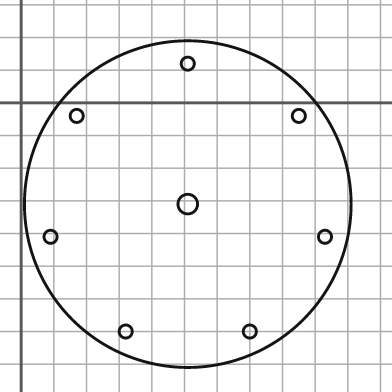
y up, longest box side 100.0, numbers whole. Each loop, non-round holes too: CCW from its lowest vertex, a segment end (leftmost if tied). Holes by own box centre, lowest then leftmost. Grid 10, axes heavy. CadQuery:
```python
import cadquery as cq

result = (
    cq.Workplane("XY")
    .moveTo(51.0, -31.0)
    .circle(50.0)
    .moveTo(32.0, -70.0)
    .circle(2.0)
    .moveTo(70.0, -70.0)
    .circle(2.0)
    .moveTo(9.0, -41.0)
    .circle(2.0)
    .moveTo(93.0, -41.0)
    .circle(2.0)
    .moveTo(51.0, -31.0)
    .circle(3.0)
    .moveTo(17.0, -4.0)
    .circle(2.0)
    .moveTo(85.0, -4.0)
    .circle(2.0)
    .moveTo(51.0, 12.0)
    .circle(2.0)
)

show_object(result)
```